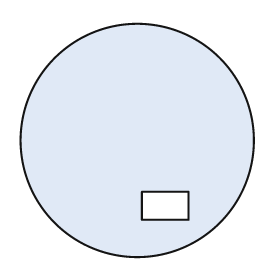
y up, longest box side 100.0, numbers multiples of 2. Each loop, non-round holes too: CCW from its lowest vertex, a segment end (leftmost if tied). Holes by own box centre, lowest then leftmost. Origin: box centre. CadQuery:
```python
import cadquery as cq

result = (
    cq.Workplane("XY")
    .moveTo(0.0, 0.0)
    .circle(50.0)
    .moveTo(2.0, -34.0)
    .lineTo(22.0, -34.0)
    .lineTo(22.0, -22.0)
    .lineTo(2.0, -22.0)
    .close()
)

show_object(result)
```